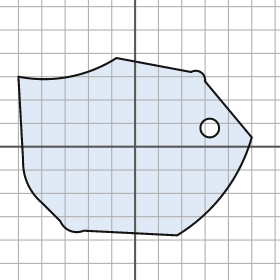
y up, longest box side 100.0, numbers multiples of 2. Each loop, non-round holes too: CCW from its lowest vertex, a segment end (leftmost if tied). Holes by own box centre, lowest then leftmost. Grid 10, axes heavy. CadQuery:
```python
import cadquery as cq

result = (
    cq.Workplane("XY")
    .moveTo(18.0, -38.0)
    .threePointArc((38.0, -20.0), (50.0, 4.0))
    .lineTo(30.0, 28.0)
    .threePointArc((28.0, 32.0), (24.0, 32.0))
    .lineTo(-8.0, 38.0)
    .threePointArc((-28.0, 30.0), (-50.0, 30.0))
    .lineTo(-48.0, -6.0)
    .threePointArc((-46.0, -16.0), (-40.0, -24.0))
    .lineTo(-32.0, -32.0)
    .threePointArc((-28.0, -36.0), (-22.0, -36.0))
    .close()
    .moveTo(32.0, 8.0)
    .circle(4.0)
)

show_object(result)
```